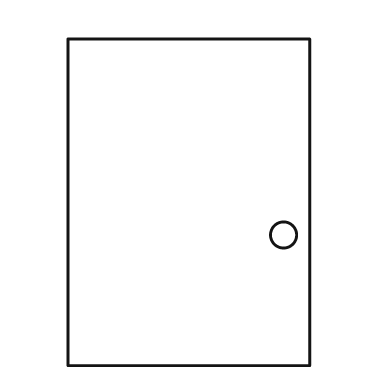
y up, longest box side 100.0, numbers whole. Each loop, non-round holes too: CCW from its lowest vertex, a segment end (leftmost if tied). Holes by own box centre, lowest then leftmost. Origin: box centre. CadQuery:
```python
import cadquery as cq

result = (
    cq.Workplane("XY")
    .moveTo(-37.0, -50.0)
    .lineTo(37.0, -50.0)
    .lineTo(37.0, 50.0)
    .lineTo(-37.0, 50.0)
    .close()
    .moveTo(29.0, -10.0)
    .circle(4.0)
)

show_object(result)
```